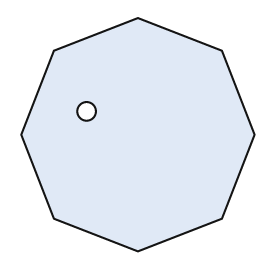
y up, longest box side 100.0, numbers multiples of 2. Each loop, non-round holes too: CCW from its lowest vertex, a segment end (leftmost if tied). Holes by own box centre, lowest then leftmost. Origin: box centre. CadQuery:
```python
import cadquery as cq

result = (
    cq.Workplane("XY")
    .moveTo(0.0, -50.0)
    .lineTo(36.0, -36.0)
    .lineTo(50.0, 0.0)
    .lineTo(36.0, 36.0)
    .lineTo(0.0, 50.0)
    .lineTo(-36.0, 36.0)
    .lineTo(-50.0, 0.0)
    .lineTo(-36.0, -36.0)
    .close()
    .moveTo(-22.0, 10.0)
    .circle(4.0)
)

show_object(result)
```